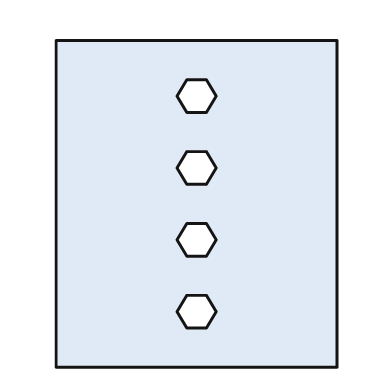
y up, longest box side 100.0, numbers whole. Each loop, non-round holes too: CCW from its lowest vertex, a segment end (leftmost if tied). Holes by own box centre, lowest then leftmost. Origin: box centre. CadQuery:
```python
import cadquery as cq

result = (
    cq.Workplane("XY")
    .moveTo(-43.0, -50.0)
    .lineTo(43.0, -50.0)
    .lineTo(43.0, 50.0)
    .lineTo(-43.0, 50.0)
    .close()
    .moveTo(-3.0, -38.0)
    .lineTo(3.0, -38.0)
    .lineTo(6.0, -33.0)
    .lineTo(3.0, -28.0)
    .lineTo(-3.0, -28.0)
    .lineTo(-6.0, -33.0)
    .close()
    .moveTo(-3.0, -16.0)
    .lineTo(3.0, -16.0)
    .lineTo(6.0, -11.0)
    .lineTo(3.0, -6.0)
    .lineTo(-3.0, -6.0)
    .lineTo(-6.0, -11.0)
    .close()
    .moveTo(-3.0, 6.0)
    .lineTo(3.0, 6.0)
    .lineTo(6.0, 11.0)
    .lineTo(3.0, 16.0)
    .lineTo(-3.0, 16.0)
    .lineTo(-6.0, 11.0)
    .close()
    .moveTo(-3.0, 28.0)
    .lineTo(3.0, 28.0)
    .lineTo(6.0, 33.0)
    .lineTo(3.0, 38.0)
    .lineTo(-3.0, 38.0)
    .lineTo(-6.0, 33.0)
    .close()
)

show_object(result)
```